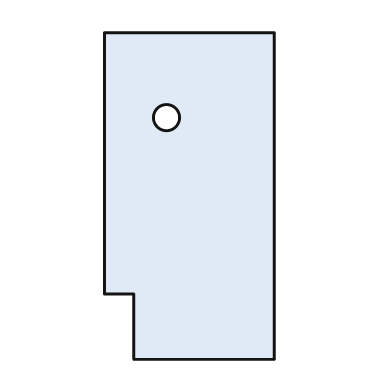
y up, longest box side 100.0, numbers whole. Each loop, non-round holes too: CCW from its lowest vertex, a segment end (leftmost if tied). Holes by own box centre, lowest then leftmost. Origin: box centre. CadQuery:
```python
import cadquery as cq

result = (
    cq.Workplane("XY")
    .moveTo(-17.0, -50.0)
    .lineTo(26.0, -50.0)
    .lineTo(26.0, 50.0)
    .lineTo(-26.0, 50.0)
    .lineTo(-26.0, -30.0)
    .lineTo(-17.0, -30.0)
    .close()
    .moveTo(-7.0, 24.0)
    .circle(4.0)
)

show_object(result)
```